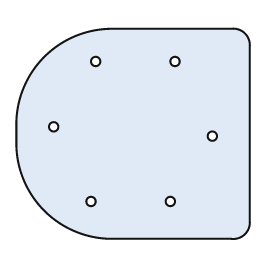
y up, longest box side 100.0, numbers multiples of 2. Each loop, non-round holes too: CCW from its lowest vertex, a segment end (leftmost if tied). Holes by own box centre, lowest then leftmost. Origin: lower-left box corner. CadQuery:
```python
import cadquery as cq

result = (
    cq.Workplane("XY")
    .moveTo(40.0, 0.0)
    .lineTo(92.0, 0.0)
    .threePointArc((98.0, 2.0), (100.0, 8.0))
    .lineTo(100.0, 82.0)
    .threePointArc((98.0, 88.0), (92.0, 90.0))
    .lineTo(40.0, 90.0)
    .threePointArc((12.0, 78.0), (0.0, 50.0))
    .lineTo(0.0, 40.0)
    .threePointArc((12.0, 12.0), (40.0, 0.0))
    .close()
    .moveTo(32.0, 16.0)
    .circle(2.0)
    .moveTo(66.0, 16.0)
    .circle(2.0)
    .moveTo(84.0, 44.0)
    .circle(2.0)
    .moveTo(16.0, 48.0)
    .circle(2.0)
    .moveTo(34.0, 76.0)
    .circle(2.0)
    .moveTo(68.0, 76.0)
    .circle(2.0)
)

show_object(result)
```